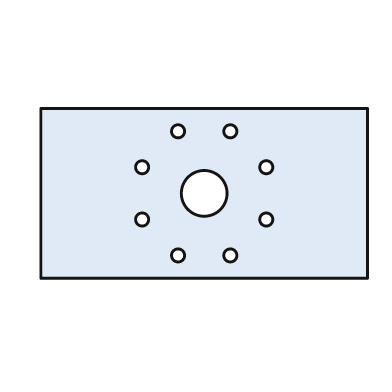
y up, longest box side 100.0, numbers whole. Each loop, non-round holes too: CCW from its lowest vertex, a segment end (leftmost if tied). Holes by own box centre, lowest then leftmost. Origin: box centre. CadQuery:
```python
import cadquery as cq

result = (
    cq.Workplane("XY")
    .moveTo(-50.0, -26.0)
    .lineTo(50.0, -26.0)
    .lineTo(50.0, 26.0)
    .lineTo(-50.0, 26.0)
    .close()
    .moveTo(-8.0, -19.0)
    .circle(2.0)
    .moveTo(8.0, -19.0)
    .circle(2.0)
    .moveTo(-19.0, -8.0)
    .circle(2.0)
    .moveTo(19.0, -8.0)
    .circle(2.0)
    .moveTo(0.0, 0.0)
    .circle(7.0)
    .moveTo(-19.0, 8.0)
    .circle(2.0)
    .moveTo(19.0, 8.0)
    .circle(2.0)
    .moveTo(-8.0, 19.0)
    .circle(2.0)
    .moveTo(8.0, 19.0)
    .circle(2.0)
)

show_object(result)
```